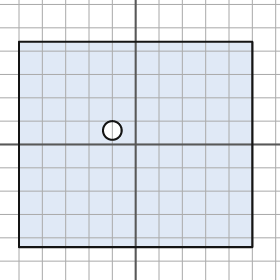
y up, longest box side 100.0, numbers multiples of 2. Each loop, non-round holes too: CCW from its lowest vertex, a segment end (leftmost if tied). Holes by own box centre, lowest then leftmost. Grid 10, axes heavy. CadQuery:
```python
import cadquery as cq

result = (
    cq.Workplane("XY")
    .moveTo(-50.0, -44.0)
    .lineTo(50.0, -44.0)
    .lineTo(50.0, 44.0)
    .lineTo(-50.0, 44.0)
    .close()
    .moveTo(-10.0, 6.0)
    .circle(4.0)
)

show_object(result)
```